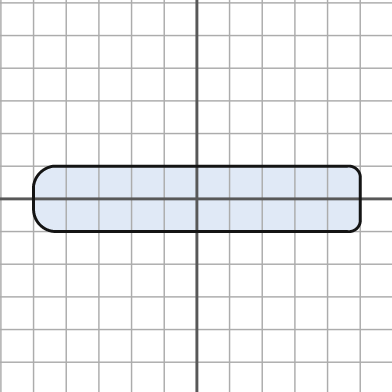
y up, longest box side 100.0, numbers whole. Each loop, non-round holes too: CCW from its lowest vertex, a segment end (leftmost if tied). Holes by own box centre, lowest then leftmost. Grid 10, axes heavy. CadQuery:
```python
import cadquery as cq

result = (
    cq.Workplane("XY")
    .moveTo(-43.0, -10.0)
    .lineTo(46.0, -10.0)
    .threePointArc((49.0, -9.0), (50.0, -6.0))
    .lineTo(50.0, 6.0)
    .threePointArc((49.0, 9.0), (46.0, 10.0))
    .lineTo(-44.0, 10.0)
    .threePointArc((-48.0, 8.0), (-50.0, 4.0))
    .lineTo(-50.0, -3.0)
    .threePointArc((-48.0, -8.0), (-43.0, -10.0))
    .close()
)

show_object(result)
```